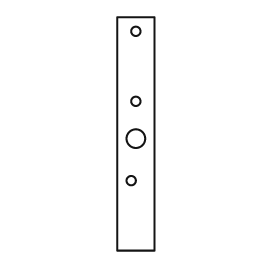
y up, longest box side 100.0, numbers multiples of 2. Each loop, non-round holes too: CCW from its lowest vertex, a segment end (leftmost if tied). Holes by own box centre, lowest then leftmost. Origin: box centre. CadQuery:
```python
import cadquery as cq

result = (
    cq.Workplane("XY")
    .moveTo(-8.0, -50.0)
    .lineTo(8.0, -50.0)
    .lineTo(8.0, 50.0)
    .lineTo(-8.0, 50.0)
    .close()
    .moveTo(-2.0, -20.0)
    .circle(2.0)
    .moveTo(0.0, -2.0)
    .circle(4.0)
    .moveTo(0.0, 14.0)
    .circle(2.0)
    .moveTo(0.0, 44.0)
    .circle(2.0)
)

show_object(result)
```